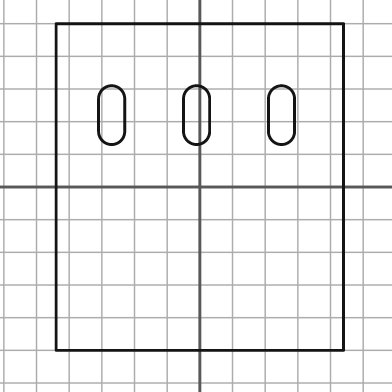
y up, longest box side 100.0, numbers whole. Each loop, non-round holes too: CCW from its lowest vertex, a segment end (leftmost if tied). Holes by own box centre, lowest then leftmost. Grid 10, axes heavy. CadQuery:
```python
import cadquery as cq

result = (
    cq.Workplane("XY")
    .moveTo(-44.0, -50.0)
    .lineTo(44.0, -50.0)
    .lineTo(44.0, 50.0)
    .lineTo(-44.0, 50.0)
    .close()
    .moveTo(-31.0, 17.0)
    .threePointArc((-27.0, 13.0), (-23.0, 17.0))
    .lineTo(-23.0, 27.0)
    .threePointArc((-27.0, 31.0), (-31.0, 27.0))
    .close()
    .moveTo(-5.0, 17.0)
    .threePointArc((-1.0, 13.0), (3.0, 17.0))
    .lineTo(3.0, 27.0)
    .threePointArc((-1.0, 31.0), (-5.0, 27.0))
    .close()
    .moveTo(21.0, 17.0)
    .threePointArc((25.0, 13.0), (29.0, 17.0))
    .lineTo(29.0, 27.0)
    .threePointArc((25.0, 31.0), (21.0, 27.0))
    .close()
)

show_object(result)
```